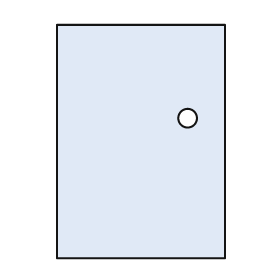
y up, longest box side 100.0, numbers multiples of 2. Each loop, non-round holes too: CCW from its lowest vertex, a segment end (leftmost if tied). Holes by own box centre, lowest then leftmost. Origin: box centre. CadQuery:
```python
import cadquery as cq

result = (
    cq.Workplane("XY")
    .moveTo(-36.0, -50.0)
    .lineTo(36.0, -50.0)
    .lineTo(36.0, 50.0)
    .lineTo(-36.0, 50.0)
    .close()
    .moveTo(20.0, 10.0)
    .circle(4.0)
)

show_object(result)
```